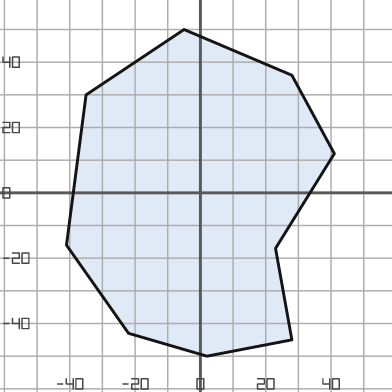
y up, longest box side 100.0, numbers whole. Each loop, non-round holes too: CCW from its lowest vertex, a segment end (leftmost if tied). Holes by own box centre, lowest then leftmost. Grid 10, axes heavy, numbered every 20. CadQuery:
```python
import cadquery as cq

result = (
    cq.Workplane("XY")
    .moveTo(2.0, -50.0)
    .lineTo(28.0, -45.0)
    .lineTo(23.0, -17.0)
    .lineTo(41.0, 12.0)
    .lineTo(28.0, 36.0)
    .lineTo(-5.0, 50.0)
    .lineTo(-35.0, 30.0)
    .lineTo(-41.0, -16.0)
    .lineTo(-22.0, -43.0)
    .close()
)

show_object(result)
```